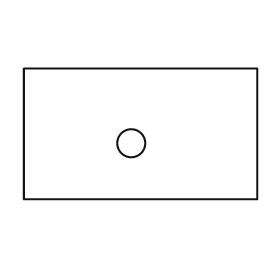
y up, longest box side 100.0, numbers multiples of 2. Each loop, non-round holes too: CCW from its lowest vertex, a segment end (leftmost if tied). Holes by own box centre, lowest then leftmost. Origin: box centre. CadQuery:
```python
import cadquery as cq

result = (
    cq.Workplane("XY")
    .moveTo(-50.0, -28.0)
    .lineTo(50.0, -28.0)
    .lineTo(50.0, 28.0)
    .lineTo(-50.0, 28.0)
    .close()
    .moveTo(-4.0, -4.0)
    .circle(6.0)
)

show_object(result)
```